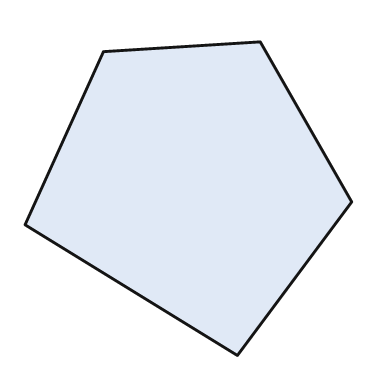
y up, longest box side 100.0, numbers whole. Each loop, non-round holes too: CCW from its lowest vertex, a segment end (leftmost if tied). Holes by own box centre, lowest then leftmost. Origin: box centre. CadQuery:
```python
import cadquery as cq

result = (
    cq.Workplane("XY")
    .moveTo(15.0, -48.0)
    .lineTo(50.0, -1.0)
    .lineTo(22.0, 48.0)
    .lineTo(-26.0, 45.0)
    .lineTo(-50.0, -8.0)
    .close()
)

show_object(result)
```